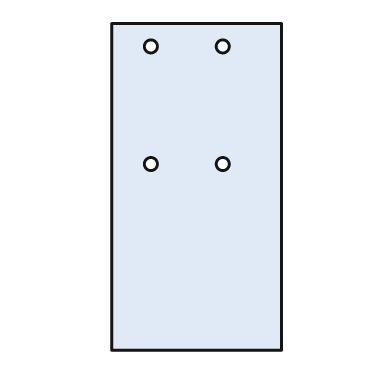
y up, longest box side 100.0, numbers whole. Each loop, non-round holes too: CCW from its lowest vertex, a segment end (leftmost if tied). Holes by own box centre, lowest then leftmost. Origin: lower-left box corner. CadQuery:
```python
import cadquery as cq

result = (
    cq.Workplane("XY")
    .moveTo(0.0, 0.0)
    .lineTo(52.0, 0.0)
    .lineTo(52.0, 100.0)
    .lineTo(0.0, 100.0)
    .close()
    .moveTo(12.0, 57.0)
    .circle(2.0)
    .moveTo(34.0, 57.0)
    .circle(2.0)
    .moveTo(12.0, 93.0)
    .circle(2.0)
    .moveTo(34.0, 93.0)
    .circle(2.0)
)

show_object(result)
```